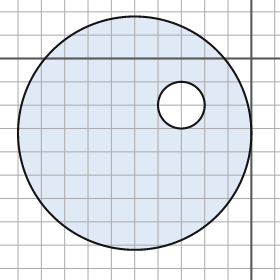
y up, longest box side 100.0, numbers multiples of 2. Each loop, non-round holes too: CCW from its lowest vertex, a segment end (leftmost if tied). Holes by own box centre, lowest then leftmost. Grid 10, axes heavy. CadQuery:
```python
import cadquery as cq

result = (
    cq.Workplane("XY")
    .moveTo(-50.0, -32.0)
    .circle(50.0)
    .moveTo(-30.0, -20.0)
    .circle(10.0)
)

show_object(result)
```